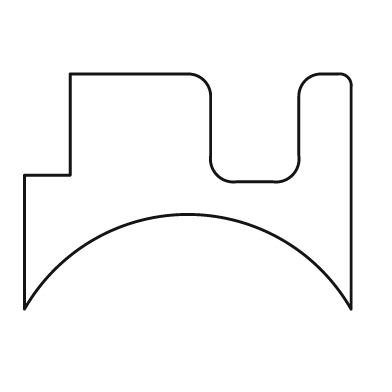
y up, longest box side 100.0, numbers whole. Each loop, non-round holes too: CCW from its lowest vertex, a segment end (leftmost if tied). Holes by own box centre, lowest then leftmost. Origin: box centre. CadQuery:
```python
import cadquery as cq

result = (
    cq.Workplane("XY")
    .moveTo(-50.0, -36.0)
    .threePointArc((0.0, -7.0), (50.0, -36.0))
    .lineTo(50.0, 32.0)
    .threePointArc((49.0, 35.0), (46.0, 36.0))
    .lineTo(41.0, 36.0)
    .threePointArc((36.0, 34.0), (34.0, 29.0))
    .lineTo(34.0, 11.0)
    .threePointArc((32.0, 5.0), (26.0, 3.0))
    .lineTo(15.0, 3.0)
    .threePointArc((9.0, 5.0), (7.0, 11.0))
    .lineTo(7.0, 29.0)
    .threePointArc((5.0, 34.0), (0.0, 36.0))
    .lineTo(-36.0, 36.0)
    .lineTo(-36.0, 5.0)
    .lineTo(-50.0, 5.0)
    .close()
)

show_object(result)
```